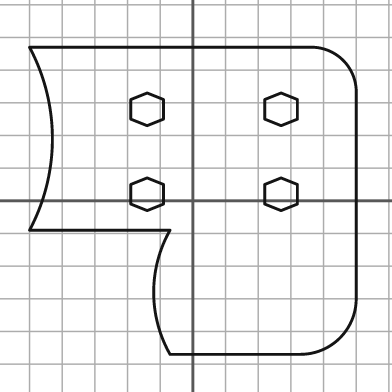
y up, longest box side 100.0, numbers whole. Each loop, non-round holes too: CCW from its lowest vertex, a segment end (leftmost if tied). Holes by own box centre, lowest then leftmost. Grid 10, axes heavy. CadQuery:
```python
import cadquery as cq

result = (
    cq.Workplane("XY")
    .moveTo(-7.0, -47.0)
    .lineTo(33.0, -47.0)
    .threePointArc((45.0, -42.0), (50.0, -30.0))
    .lineTo(50.0, 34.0)
    .threePointArc((46.0, 43.0), (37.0, 47.0))
    .lineTo(-50.0, 47.0)
    .threePointArc((-43.0, 19.0), (-50.0, -9.0))
    .lineTo(-7.0, -9.0)
    .threePointArc((-12.0, -28.0), (-7.0, -47.0))
    .close()
    .moveTo(-14.0, -3.0)
    .lineTo(-9.0, -1.0)
    .lineTo(-9.0, 5.0)
    .lineTo(-14.0, 7.0)
    .lineTo(-19.0, 5.0)
    .lineTo(-19.0, -1.0)
    .close()
    .moveTo(27.0, -3.0)
    .lineTo(32.0, -1.0)
    .lineTo(32.0, 5.0)
    .lineTo(27.0, 7.0)
    .lineTo(22.0, 5.0)
    .lineTo(22.0, -1.0)
    .close()
    .moveTo(-14.0, 23.0)
    .lineTo(-9.0, 25.0)
    .lineTo(-9.0, 31.0)
    .lineTo(-14.0, 33.0)
    .lineTo(-19.0, 31.0)
    .lineTo(-19.0, 25.0)
    .close()
    .moveTo(27.0, 23.0)
    .lineTo(32.0, 25.0)
    .lineTo(32.0, 31.0)
    .lineTo(27.0, 33.0)
    .lineTo(22.0, 31.0)
    .lineTo(22.0, 25.0)
    .close()
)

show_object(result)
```